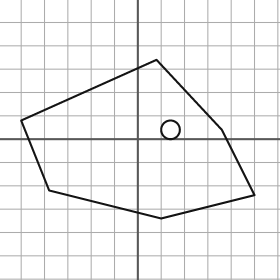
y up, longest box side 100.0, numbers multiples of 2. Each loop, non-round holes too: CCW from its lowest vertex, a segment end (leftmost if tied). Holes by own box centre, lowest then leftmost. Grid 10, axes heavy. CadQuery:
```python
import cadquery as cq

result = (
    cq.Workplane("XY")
    .moveTo(10.0, -34.0)
    .lineTo(50.0, -24.0)
    .lineTo(36.0, 4.0)
    .lineTo(8.0, 34.0)
    .lineTo(-50.0, 8.0)
    .lineTo(-38.0, -22.0)
    .close()
    .moveTo(14.0, 4.0)
    .circle(4.0)
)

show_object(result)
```